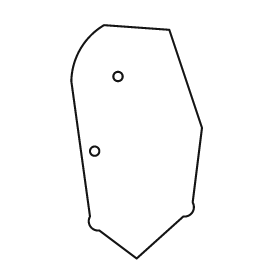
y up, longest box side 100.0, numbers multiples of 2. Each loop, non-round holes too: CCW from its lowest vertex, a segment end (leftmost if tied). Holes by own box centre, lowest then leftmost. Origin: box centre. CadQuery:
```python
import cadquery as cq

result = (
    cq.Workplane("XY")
    .moveTo(0.0, -50.0)
    .lineTo(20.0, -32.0)
    .threePointArc((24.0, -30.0), (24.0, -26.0))
    .lineTo(28.0, 6.0)
    .lineTo(14.0, 48.0)
    .lineTo(-14.0, 50.0)
    .threePointArc((-24.0, 40.0), (-28.0, 26.0))
    .lineTo(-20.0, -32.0)
    .threePointArc((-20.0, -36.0), (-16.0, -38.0))
    .close()
    .moveTo(-18.0, -4.0)
    .circle(2.0)
    .moveTo(-8.0, 28.0)
    .circle(2.0)
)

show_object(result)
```